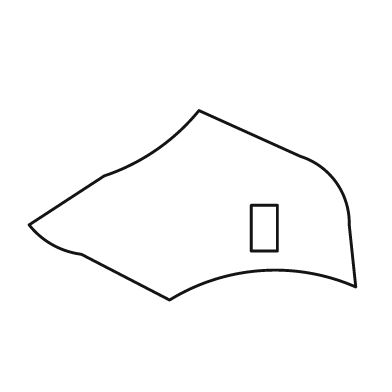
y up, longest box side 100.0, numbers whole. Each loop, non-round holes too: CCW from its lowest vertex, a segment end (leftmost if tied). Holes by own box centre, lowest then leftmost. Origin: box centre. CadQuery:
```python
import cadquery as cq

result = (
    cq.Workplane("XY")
    .moveTo(-7.0, -29.0)
    .threePointArc((21.0, -20.0), (50.0, -25.0))
    .lineTo(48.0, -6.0)
    .threePointArc((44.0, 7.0), (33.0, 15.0))
    .lineTo(2.0, 29.0)
    .threePointArc((-11.0, 17.0), (-27.0, 9.0))
    .lineTo(-50.0, -6.0)
    .threePointArc((-43.0, -12.0), (-34.0, -15.0))
    .close()
    .moveTo(18.0, -14.0)
    .lineTo(26.0, -14.0)
    .lineTo(26.0, 0.0)
    .lineTo(18.0, 0.0)
    .close()
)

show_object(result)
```